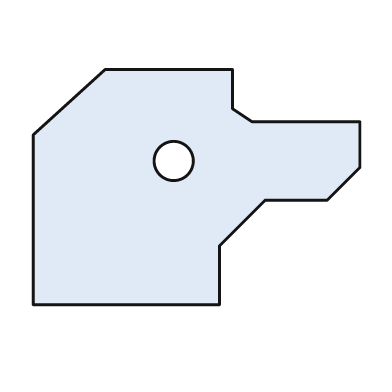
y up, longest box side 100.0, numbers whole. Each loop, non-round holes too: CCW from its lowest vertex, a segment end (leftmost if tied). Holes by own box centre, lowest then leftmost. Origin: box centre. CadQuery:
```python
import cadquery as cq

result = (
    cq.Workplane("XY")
    .moveTo(-50.0, -36.0)
    .lineTo(7.0, -36.0)
    .lineTo(7.0, -18.0)
    .lineTo(21.0, -4.0)
    .lineTo(40.0, -4.0)
    .lineTo(50.0, 6.0)
    .lineTo(50.0, 20.0)
    .lineTo(17.0, 20.0)
    .lineTo(11.0, 24.0)
    .lineTo(11.0, 36.0)
    .lineTo(-28.0, 36.0)
    .lineTo(-50.0, 16.0)
    .close()
    .moveTo(-7.0, 8.0)
    .circle(6.0)
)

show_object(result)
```